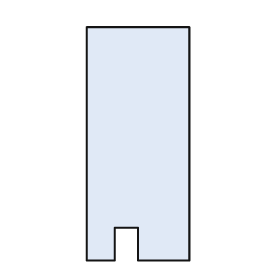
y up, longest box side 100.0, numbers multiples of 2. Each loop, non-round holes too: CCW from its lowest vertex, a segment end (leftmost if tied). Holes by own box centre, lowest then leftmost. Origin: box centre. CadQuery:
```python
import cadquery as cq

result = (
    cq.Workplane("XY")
    .moveTo(-22.0, -50.0)
    .lineTo(-10.0, -50.0)
    .lineTo(-10.0, -36.0)
    .lineTo(0.0, -36.0)
    .lineTo(0.0, -50.0)
    .lineTo(22.0, -50.0)
    .lineTo(22.0, 50.0)
    .lineTo(-22.0, 50.0)
    .close()
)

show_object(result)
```